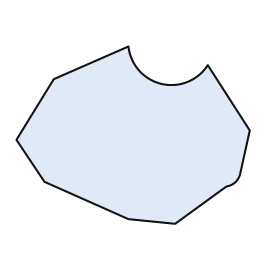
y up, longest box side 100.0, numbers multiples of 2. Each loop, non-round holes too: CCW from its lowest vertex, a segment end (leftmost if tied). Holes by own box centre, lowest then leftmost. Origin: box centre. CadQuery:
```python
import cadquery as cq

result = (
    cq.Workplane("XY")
    .moveTo(18.0, -38.0)
    .lineTo(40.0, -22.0)
    .threePointArc((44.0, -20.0), (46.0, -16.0))
    .lineTo(50.0, 2.0)
    .lineTo(32.0, 30.0)
    .threePointArc((12.0, 22.0), (-2.0, 38.0))
    .lineTo(-34.0, 24.0)
    .lineTo(-50.0, -2.0)
    .lineTo(-38.0, -20.0)
    .lineTo(-2.0, -36.0)
    .close()
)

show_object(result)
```